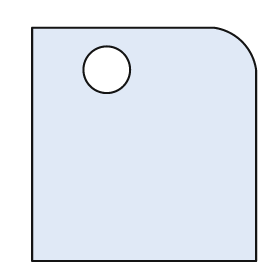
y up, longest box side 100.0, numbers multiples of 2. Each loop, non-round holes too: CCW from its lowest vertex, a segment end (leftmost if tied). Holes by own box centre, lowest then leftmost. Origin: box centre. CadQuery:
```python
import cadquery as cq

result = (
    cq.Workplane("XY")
    .moveTo(-48.0, -50.0)
    .lineTo(48.0, -50.0)
    .lineTo(48.0, 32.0)
    .threePointArc((42.0, 44.0), (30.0, 50.0))
    .lineTo(-48.0, 50.0)
    .close()
    .moveTo(-16.0, 32.0)
    .circle(10.0)
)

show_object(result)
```